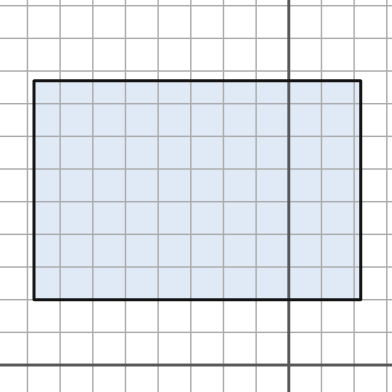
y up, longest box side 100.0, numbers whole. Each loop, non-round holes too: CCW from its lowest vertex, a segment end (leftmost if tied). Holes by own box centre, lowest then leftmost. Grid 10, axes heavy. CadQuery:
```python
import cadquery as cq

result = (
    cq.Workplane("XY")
    .moveTo(-78.0, 20.0)
    .lineTo(22.0, 20.0)
    .lineTo(22.0, 87.0)
    .lineTo(-78.0, 87.0)
    .close()
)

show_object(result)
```